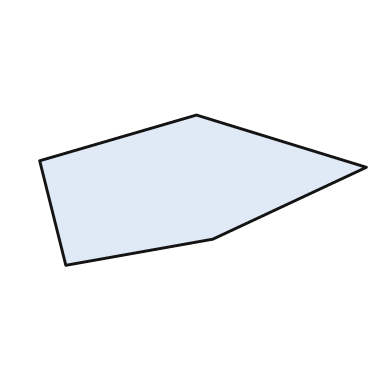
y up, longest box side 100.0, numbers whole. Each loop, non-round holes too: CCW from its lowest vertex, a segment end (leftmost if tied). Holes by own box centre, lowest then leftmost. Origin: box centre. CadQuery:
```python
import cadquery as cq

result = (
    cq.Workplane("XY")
    .moveTo(-42.0, -23.0)
    .lineTo(3.0, -15.0)
    .lineTo(50.0, 7.0)
    .lineTo(-2.0, 23.0)
    .lineTo(-50.0, 9.0)
    .close()
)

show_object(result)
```